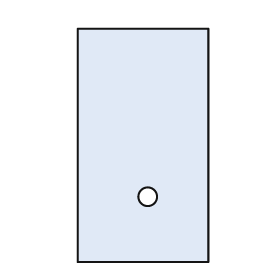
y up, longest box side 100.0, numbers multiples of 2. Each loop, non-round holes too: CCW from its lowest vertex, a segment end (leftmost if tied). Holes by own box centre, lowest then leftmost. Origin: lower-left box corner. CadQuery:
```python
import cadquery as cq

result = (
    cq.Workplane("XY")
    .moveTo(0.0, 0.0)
    .lineTo(56.0, 0.0)
    .lineTo(56.0, 100.0)
    .lineTo(0.0, 100.0)
    .close()
    .moveTo(30.0, 28.0)
    .circle(4.0)
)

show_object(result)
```